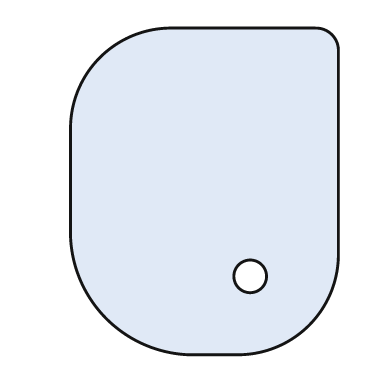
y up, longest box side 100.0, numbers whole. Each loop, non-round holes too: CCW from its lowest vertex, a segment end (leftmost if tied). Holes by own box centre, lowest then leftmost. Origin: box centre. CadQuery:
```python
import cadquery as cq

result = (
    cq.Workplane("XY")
    .moveTo(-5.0, -50.0)
    .lineTo(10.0, -50.0)
    .threePointArc((32.0, -41.0), (41.0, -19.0))
    .lineTo(41.0, 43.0)
    .threePointArc((39.0, 48.0), (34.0, 50.0))
    .lineTo(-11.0, 50.0)
    .threePointArc((-32.0, 41.0), (-41.0, 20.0))
    .lineTo(-41.0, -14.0)
    .threePointArc((-30.0, -39.0), (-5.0, -50.0))
    .close()
    .moveTo(14.0, -26.0)
    .circle(5.0)
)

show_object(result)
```